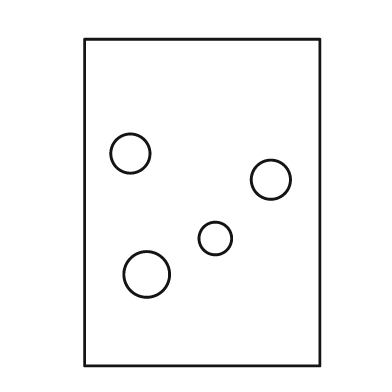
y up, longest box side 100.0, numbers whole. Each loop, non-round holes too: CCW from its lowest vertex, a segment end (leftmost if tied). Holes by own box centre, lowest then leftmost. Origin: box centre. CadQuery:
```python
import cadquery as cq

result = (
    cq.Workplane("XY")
    .moveTo(-36.0, -50.0)
    .lineTo(36.0, -50.0)
    .lineTo(36.0, 50.0)
    .lineTo(-36.0, 50.0)
    .close()
    .moveTo(-17.0, -22.0)
    .circle(7.0)
    .moveTo(4.0, -11.0)
    .circle(5.0)
    .moveTo(21.0, 7.0)
    .circle(6.0)
    .moveTo(-22.0, 15.0)
    .circle(6.0)
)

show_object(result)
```